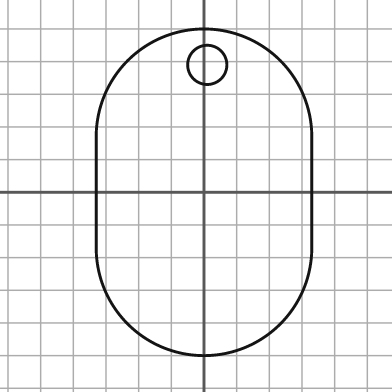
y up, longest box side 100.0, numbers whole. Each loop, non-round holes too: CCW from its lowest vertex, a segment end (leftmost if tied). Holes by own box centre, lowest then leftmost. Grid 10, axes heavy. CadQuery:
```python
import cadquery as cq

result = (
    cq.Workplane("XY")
    .moveTo(-33.0, -17.0)
    .threePointArc((0.0, -50.0), (33.0, -17.0))
    .lineTo(33.0, 17.0)
    .threePointArc((0.0, 50.0), (-33.0, 17.0))
    .close()
    .moveTo(1.0, 39.0)
    .circle(6.0)
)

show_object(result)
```